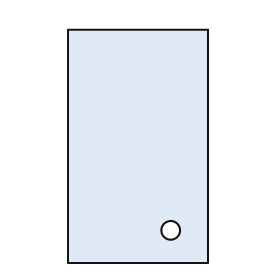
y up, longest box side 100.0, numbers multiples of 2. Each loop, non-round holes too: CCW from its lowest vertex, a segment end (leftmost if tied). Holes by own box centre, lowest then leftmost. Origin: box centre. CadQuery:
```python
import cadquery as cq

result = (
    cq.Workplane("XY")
    .moveTo(-30.0, -50.0)
    .lineTo(30.0, -50.0)
    .lineTo(30.0, 50.0)
    .lineTo(-30.0, 50.0)
    .close()
    .moveTo(14.0, -36.0)
    .circle(4.0)
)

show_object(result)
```